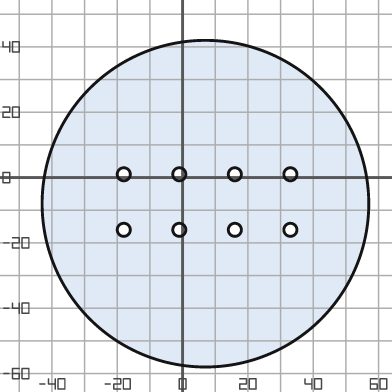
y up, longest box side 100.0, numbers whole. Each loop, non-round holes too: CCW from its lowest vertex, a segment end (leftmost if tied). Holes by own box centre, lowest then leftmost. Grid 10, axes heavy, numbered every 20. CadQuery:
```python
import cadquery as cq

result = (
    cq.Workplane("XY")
    .moveTo(7.0, -8.0)
    .circle(50.0)
    .moveTo(-18.0, -16.0)
    .circle(2.0)
    .moveTo(-1.0, -16.0)
    .circle(2.0)
    .moveTo(16.0, -16.0)
    .circle(2.0)
    .moveTo(33.0, -16.0)
    .circle(2.0)
    .moveTo(-18.0, 1.0)
    .circle(2.0)
    .moveTo(-1.0, 1.0)
    .circle(2.0)
    .moveTo(16.0, 1.0)
    .circle(2.0)
    .moveTo(33.0, 1.0)
    .circle(2.0)
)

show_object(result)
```